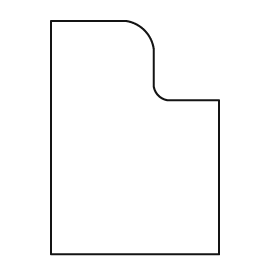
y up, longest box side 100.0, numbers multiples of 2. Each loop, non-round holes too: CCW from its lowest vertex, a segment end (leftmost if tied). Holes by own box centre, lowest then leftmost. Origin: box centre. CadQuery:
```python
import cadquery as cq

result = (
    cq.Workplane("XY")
    .moveTo(-36.0, -50.0)
    .lineTo(36.0, -50.0)
    .lineTo(36.0, 16.0)
    .lineTo(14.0, 16.0)
    .threePointArc((10.0, 18.0), (8.0, 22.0))
    .lineTo(8.0, 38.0)
    .threePointArc((4.0, 46.0), (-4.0, 50.0))
    .lineTo(-36.0, 50.0)
    .close()
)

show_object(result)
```